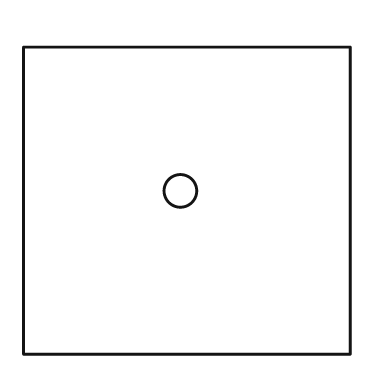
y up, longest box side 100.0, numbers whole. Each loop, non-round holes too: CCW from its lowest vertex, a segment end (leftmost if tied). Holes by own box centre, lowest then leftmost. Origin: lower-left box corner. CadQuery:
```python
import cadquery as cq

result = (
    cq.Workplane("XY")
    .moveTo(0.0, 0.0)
    .lineTo(100.0, 0.0)
    .lineTo(100.0, 94.0)
    .lineTo(0.0, 94.0)
    .close()
    .moveTo(48.0, 50.0)
    .circle(5.0)
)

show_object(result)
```